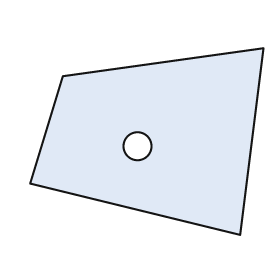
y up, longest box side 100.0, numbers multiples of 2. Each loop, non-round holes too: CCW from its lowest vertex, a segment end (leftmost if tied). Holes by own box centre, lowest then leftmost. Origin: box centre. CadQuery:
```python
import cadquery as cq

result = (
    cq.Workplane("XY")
    .moveTo(40.0, -40.0)
    .lineTo(50.0, 40.0)
    .lineTo(-36.0, 28.0)
    .lineTo(-50.0, -18.0)
    .close()
    .moveTo(-4.0, -2.0)
    .circle(6.0)
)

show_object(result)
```